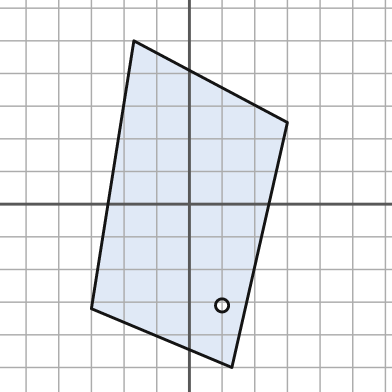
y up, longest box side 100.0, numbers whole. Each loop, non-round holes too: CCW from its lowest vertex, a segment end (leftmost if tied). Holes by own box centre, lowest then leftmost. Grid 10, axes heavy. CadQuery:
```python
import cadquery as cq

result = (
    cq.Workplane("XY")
    .moveTo(13.0, -50.0)
    .lineTo(30.0, 25.0)
    .lineTo(-17.0, 50.0)
    .lineTo(-30.0, -32.0)
    .close()
    .moveTo(10.0, -31.0)
    .circle(2.0)
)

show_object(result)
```